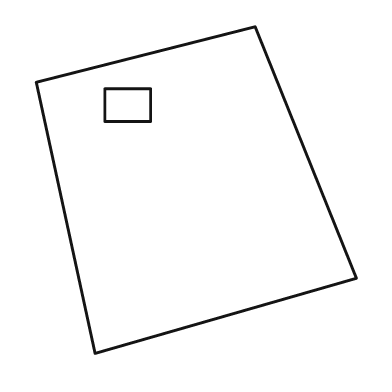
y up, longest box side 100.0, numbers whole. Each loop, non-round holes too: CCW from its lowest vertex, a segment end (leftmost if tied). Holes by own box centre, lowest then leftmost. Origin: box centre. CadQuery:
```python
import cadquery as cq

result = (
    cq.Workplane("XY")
    .moveTo(-31.0, -50.0)
    .lineTo(49.0, -27.0)
    .lineTo(18.0, 50.0)
    .lineTo(-49.0, 33.0)
    .close()
    .moveTo(-28.0, 21.0)
    .lineTo(-14.0, 21.0)
    .lineTo(-14.0, 31.0)
    .lineTo(-28.0, 31.0)
    .close()
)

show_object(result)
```